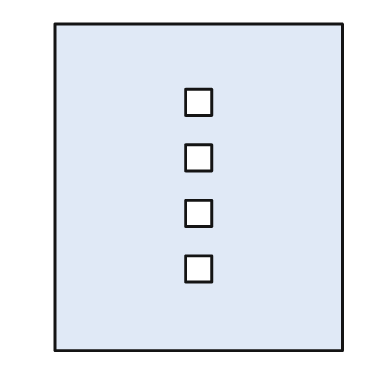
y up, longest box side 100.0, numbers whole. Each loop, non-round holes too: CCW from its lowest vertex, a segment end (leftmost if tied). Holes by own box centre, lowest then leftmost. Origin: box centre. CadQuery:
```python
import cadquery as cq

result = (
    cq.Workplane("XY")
    .moveTo(-44.0, -50.0)
    .lineTo(44.0, -50.0)
    .lineTo(44.0, 50.0)
    .lineTo(-44.0, 50.0)
    .close()
    .moveTo(-4.0, -29.0)
    .lineTo(4.0, -29.0)
    .lineTo(4.0, -21.0)
    .lineTo(-4.0, -21.0)
    .close()
    .moveTo(-4.0, -12.0)
    .lineTo(4.0, -12.0)
    .lineTo(4.0, -4.0)
    .lineTo(-4.0, -4.0)
    .close()
    .moveTo(-4.0, 5.0)
    .lineTo(4.0, 5.0)
    .lineTo(4.0, 13.0)
    .lineTo(-4.0, 13.0)
    .close()
    .moveTo(-4.0, 22.0)
    .lineTo(4.0, 22.0)
    .lineTo(4.0, 30.0)
    .lineTo(-4.0, 30.0)
    .close()
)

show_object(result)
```